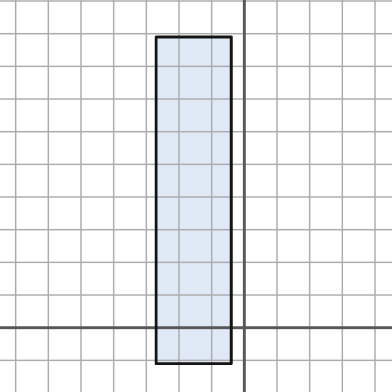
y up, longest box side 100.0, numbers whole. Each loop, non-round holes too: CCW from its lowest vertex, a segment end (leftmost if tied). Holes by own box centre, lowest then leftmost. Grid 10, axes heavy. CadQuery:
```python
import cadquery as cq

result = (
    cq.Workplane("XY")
    .moveTo(-27.0, -11.0)
    .lineTo(-4.0, -11.0)
    .lineTo(-4.0, 89.0)
    .lineTo(-27.0, 89.0)
    .close()
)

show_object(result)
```